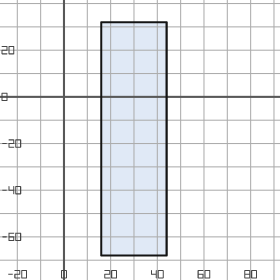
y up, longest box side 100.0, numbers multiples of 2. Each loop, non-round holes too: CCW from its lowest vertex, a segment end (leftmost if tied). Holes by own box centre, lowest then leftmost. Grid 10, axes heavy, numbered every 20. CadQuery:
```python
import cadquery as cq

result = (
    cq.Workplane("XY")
    .moveTo(16.0, -68.0)
    .lineTo(44.0, -68.0)
    .lineTo(44.0, 32.0)
    .lineTo(16.0, 32.0)
    .close()
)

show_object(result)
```